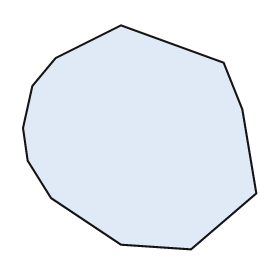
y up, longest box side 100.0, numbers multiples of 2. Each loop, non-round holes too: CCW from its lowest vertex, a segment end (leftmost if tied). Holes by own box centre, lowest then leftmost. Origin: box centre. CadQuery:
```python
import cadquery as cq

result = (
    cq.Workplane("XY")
    .moveTo(22.0, -48.0)
    .lineTo(50.0, -24.0)
    .lineTo(44.0, 12.0)
    .lineTo(36.0, 32.0)
    .lineTo(-8.0, 48.0)
    .lineTo(-36.0, 34.0)
    .lineTo(-46.0, 22.0)
    .lineTo(-50.0, 4.0)
    .lineTo(-48.0, -10.0)
    .lineTo(-38.0, -26.0)
    .lineTo(-8.0, -46.0)
    .close()
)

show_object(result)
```